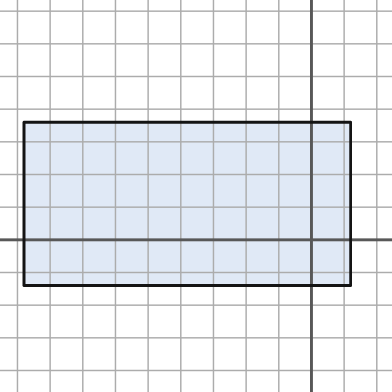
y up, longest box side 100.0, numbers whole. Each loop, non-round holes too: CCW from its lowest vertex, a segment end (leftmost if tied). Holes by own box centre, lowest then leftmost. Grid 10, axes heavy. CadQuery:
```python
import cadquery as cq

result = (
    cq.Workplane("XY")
    .moveTo(-88.0, -14.0)
    .lineTo(12.0, -14.0)
    .lineTo(12.0, 36.0)
    .lineTo(-88.0, 36.0)
    .close()
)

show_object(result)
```